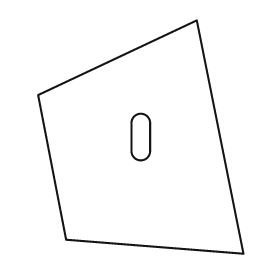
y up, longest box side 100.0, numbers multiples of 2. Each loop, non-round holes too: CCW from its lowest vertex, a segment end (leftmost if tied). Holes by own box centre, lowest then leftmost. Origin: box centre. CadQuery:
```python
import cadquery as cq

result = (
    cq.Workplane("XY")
    .moveTo(44.0, -50.0)
    .lineTo(24.0, 50.0)
    .lineTo(-44.0, 18.0)
    .lineTo(-32.0, -44.0)
    .close()
    .moveTo(-4.0, -6.0)
    .threePointArc((0.0, -10.0), (4.0, -6.0))
    .lineTo(4.0, 6.0)
    .threePointArc((0.0, 10.0), (-4.0, 6.0))
    .close()
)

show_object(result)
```